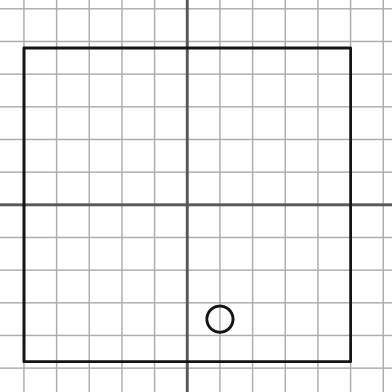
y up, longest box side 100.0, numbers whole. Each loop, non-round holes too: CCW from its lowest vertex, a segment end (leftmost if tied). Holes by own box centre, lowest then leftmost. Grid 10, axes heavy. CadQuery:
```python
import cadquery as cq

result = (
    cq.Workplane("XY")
    .moveTo(-50.0, -48.0)
    .lineTo(50.0, -48.0)
    .lineTo(50.0, 48.0)
    .lineTo(-50.0, 48.0)
    .close()
    .moveTo(10.0, -35.0)
    .circle(4.0)
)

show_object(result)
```